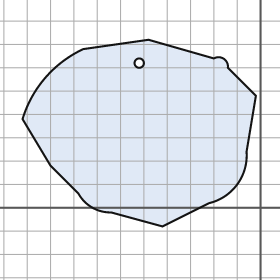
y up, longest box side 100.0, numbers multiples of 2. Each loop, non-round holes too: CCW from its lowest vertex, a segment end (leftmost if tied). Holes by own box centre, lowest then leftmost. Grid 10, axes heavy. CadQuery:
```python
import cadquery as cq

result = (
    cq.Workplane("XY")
    .moveTo(-42.0, -8.0)
    .lineTo(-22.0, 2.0)
    .threePointArc((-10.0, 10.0), (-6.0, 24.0))
    .lineTo(-2.0, 48.0)
    .lineTo(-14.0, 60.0)
    .threePointArc((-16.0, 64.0), (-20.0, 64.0))
    .lineTo(-48.0, 72.0)
    .lineTo(-76.0, 68.0)
    .threePointArc((-92.0, 56.0), (-102.0, 38.0))
    .lineTo(-90.0, 18.0)
    .lineTo(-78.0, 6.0)
    .threePointArc((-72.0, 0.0), (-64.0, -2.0))
    .close()
    .moveTo(-52.0, 62.0)
    .circle(2.0)
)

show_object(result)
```